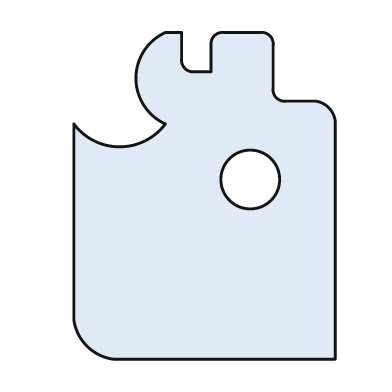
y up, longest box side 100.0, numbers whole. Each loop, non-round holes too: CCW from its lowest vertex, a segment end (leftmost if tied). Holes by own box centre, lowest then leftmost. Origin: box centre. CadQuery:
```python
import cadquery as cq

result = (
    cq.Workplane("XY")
    .moveTo(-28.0, -50.0)
    .lineTo(40.0, -50.0)
    .lineTo(40.0, 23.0)
    .threePointArc((38.0, 27.0), (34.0, 29.0))
    .lineTo(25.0, 29.0)
    .threePointArc((22.0, 30.0), (21.0, 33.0))
    .lineTo(21.0, 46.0)
    .threePointArc((20.0, 49.0), (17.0, 50.0))
    .lineTo(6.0, 50.0)
    .threePointArc((3.0, 49.0), (2.0, 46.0))
    .lineTo(2.0, 38.0)
    .lineTo(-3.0, 38.0)
    .threePointArc((-6.0, 39.0), (-7.0, 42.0))
    .lineTo(-7.0, 50.0)
    .lineTo(-12.0, 50.0)
    .threePointArc((-21.0, 36.0), (-12.0, 22.0))
    .threePointArc((-26.0, 15.0), (-40.0, 22.0))
    .lineTo(-40.0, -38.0)
    .threePointArc((-36.0, -46.0), (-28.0, -50.0))
    .close()
    .moveTo(14.0, 5.0)
    .circle(9.0)
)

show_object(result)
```